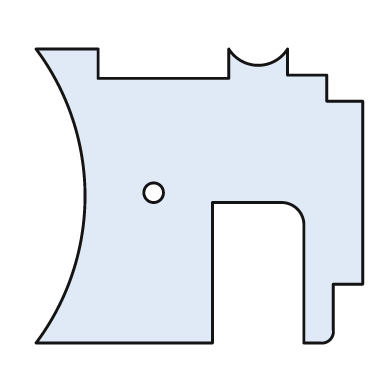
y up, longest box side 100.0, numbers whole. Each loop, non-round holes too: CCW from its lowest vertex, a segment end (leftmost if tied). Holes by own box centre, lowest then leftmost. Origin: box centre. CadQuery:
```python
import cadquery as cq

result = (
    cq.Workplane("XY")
    .moveTo(-50.0, -45.0)
    .lineTo(4.0, -45.0)
    .lineTo(4.0, -2.0)
    .lineTo(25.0, -2.0)
    .threePointArc((30.0, -4.0), (32.0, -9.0))
    .lineTo(32.0, -45.0)
    .lineTo(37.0, -45.0)
    .threePointArc((40.0, -44.0), (41.0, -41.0))
    .lineTo(41.0, -27.0)
    .lineTo(50.0, -27.0)
    .lineTo(50.0, 29.0)
    .lineTo(39.0, 29.0)
    .lineTo(39.0, 37.0)
    .lineTo(27.0, 37.0)
    .lineTo(27.0, 45.0)
    .threePointArc((18.0, 40.0), (9.0, 45.0))
    .lineTo(9.0, 36.0)
    .lineTo(-31.0, 36.0)
    .lineTo(-31.0, 45.0)
    .lineTo(-50.0, 45.0)
    .threePointArc((-35.0, 0.0), (-50.0, -45.0))
    .close()
    .moveTo(-14.0, 1.0)
    .circle(3.0)
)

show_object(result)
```